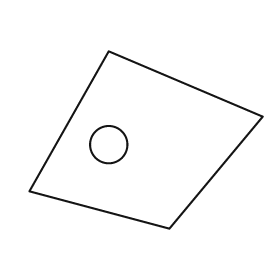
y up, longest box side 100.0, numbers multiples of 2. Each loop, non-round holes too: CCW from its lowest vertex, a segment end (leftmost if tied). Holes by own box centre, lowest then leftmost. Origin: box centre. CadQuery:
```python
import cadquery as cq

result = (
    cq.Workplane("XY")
    .moveTo(10.0, -38.0)
    .lineTo(50.0, 10.0)
    .lineTo(-16.0, 38.0)
    .lineTo(-50.0, -22.0)
    .close()
    .moveTo(-16.0, -2.0)
    .circle(8.0)
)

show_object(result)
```